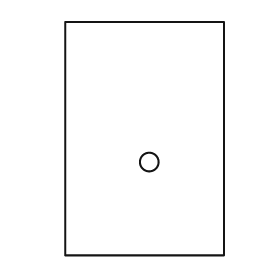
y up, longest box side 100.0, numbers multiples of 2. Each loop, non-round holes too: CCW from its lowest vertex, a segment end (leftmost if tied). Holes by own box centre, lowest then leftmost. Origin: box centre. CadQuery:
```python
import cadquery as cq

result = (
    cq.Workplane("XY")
    .moveTo(-34.0, -50.0)
    .lineTo(34.0, -50.0)
    .lineTo(34.0, 50.0)
    .lineTo(-34.0, 50.0)
    .close()
    .moveTo(2.0, -10.0)
    .circle(4.0)
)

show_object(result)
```